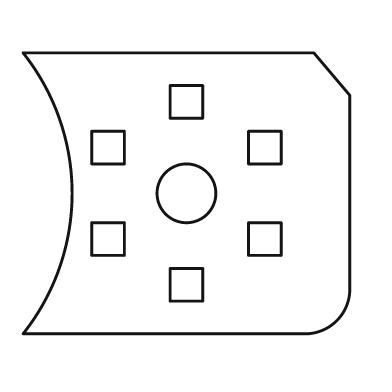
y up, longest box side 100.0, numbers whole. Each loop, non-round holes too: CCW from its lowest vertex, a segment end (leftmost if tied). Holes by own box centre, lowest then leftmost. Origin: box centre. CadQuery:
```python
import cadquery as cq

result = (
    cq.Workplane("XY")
    .moveTo(-50.0, -43.0)
    .lineTo(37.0, -43.0)
    .threePointArc((46.0, -39.0), (50.0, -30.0))
    .lineTo(50.0, 30.0)
    .lineTo(39.0, 43.0)
    .lineTo(-50.0, 43.0)
    .threePointArc((-35.0, 0.0), (-50.0, -43.0))
    .close()
    .moveTo(-5.0, -33.0)
    .lineTo(5.0, -33.0)
    .lineTo(5.0, -23.0)
    .lineTo(-5.0, -23.0)
    .close()
    .moveTo(-29.0, -19.0)
    .lineTo(-19.0, -19.0)
    .lineTo(-19.0, -9.0)
    .lineTo(-29.0, -9.0)
    .close()
    .moveTo(19.0, -19.0)
    .lineTo(29.0, -19.0)
    .lineTo(29.0, -9.0)
    .lineTo(19.0, -9.0)
    .close()
    .moveTo(0.0, 0.0)
    .circle(9.0)
    .moveTo(-29.0, 9.0)
    .lineTo(-19.0, 9.0)
    .lineTo(-19.0, 19.0)
    .lineTo(-29.0, 19.0)
    .close()
    .moveTo(19.0, 9.0)
    .lineTo(29.0, 9.0)
    .lineTo(29.0, 19.0)
    .lineTo(19.0, 19.0)
    .close()
    .moveTo(-5.0, 23.0)
    .lineTo(5.0, 23.0)
    .lineTo(5.0, 33.0)
    .lineTo(-5.0, 33.0)
    .close()
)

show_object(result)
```